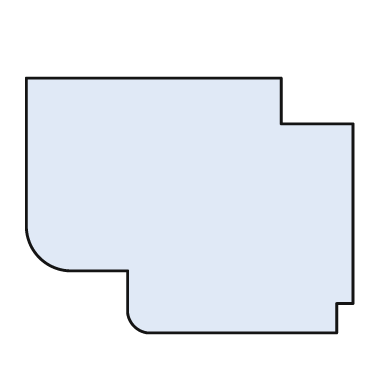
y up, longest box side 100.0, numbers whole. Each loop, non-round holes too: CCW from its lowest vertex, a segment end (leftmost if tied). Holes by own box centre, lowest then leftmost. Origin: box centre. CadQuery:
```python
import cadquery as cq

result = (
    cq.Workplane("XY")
    .moveTo(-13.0, -39.0)
    .lineTo(45.0, -39.0)
    .lineTo(45.0, -30.0)
    .lineTo(50.0, -30.0)
    .lineTo(50.0, 25.0)
    .lineTo(28.0, 25.0)
    .lineTo(28.0, 39.0)
    .lineTo(-50.0, 39.0)
    .lineTo(-50.0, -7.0)
    .threePointArc((-46.0, -16.0), (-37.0, -20.0))
    .lineTo(-19.0, -20.0)
    .lineTo(-19.0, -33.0)
    .threePointArc((-17.0, -37.0), (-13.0, -39.0))
    .close()
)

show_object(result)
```